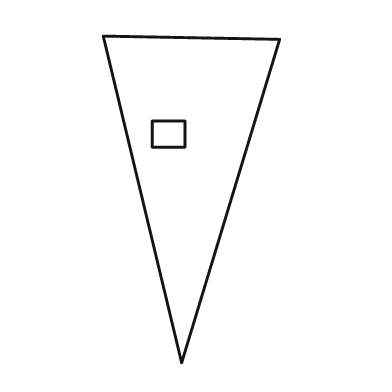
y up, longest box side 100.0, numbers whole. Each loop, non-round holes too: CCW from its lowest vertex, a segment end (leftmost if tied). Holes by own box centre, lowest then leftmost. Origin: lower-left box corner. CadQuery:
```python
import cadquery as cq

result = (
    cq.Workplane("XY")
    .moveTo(24.0, 0.0)
    .lineTo(54.0, 99.0)
    .lineTo(0.0, 100.0)
    .close()
    .moveTo(15.0, 66.0)
    .lineTo(25.0, 66.0)
    .lineTo(25.0, 74.0)
    .lineTo(15.0, 74.0)
    .close()
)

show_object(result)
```